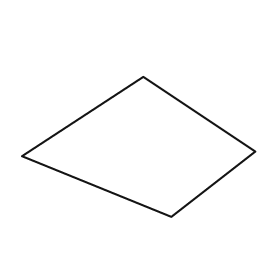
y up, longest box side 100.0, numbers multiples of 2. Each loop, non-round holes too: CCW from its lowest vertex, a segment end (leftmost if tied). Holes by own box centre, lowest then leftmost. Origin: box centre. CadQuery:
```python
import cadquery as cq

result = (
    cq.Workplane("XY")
    .moveTo(14.0, -30.0)
    .lineTo(50.0, -2.0)
    .lineTo(2.0, 30.0)
    .lineTo(-50.0, -4.0)
    .close()
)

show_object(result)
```